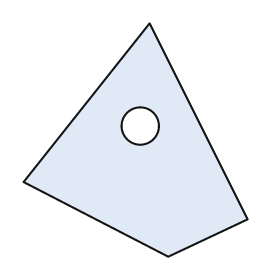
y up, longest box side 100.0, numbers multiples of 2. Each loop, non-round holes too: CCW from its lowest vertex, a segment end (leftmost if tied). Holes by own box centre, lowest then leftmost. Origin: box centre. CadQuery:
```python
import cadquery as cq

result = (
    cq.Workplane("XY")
    .moveTo(14.0, -50.0)
    .lineTo(48.0, -34.0)
    .lineTo(6.0, 50.0)
    .lineTo(-48.0, -18.0)
    .close()
    .moveTo(2.0, 6.0)
    .circle(8.0)
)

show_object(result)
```